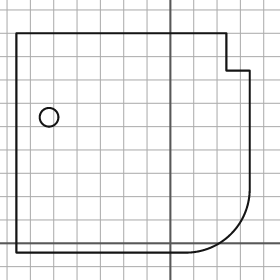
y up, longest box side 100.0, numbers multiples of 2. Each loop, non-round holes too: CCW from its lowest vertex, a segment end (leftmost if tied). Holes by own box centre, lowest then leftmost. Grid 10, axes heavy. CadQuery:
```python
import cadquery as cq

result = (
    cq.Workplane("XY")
    .moveTo(-66.0, -4.0)
    .lineTo(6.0, -4.0)
    .threePointArc((26.0, 4.0), (34.0, 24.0))
    .lineTo(34.0, 74.0)
    .lineTo(24.0, 74.0)
    .lineTo(24.0, 90.0)
    .lineTo(-66.0, 90.0)
    .close()
    .moveTo(-52.0, 54.0)
    .circle(4.0)
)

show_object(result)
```